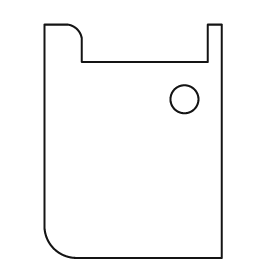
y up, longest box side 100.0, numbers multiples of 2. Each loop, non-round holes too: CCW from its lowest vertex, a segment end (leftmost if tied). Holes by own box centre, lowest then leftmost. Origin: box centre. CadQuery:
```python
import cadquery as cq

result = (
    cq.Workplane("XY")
    .moveTo(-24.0, -50.0)
    .lineTo(38.0, -50.0)
    .lineTo(38.0, 50.0)
    .lineTo(32.0, 50.0)
    .lineTo(32.0, 34.0)
    .lineTo(-22.0, 34.0)
    .lineTo(-22.0, 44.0)
    .threePointArc((-24.0, 48.0), (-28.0, 50.0))
    .lineTo(-38.0, 50.0)
    .lineTo(-38.0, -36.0)
    .threePointArc((-34.0, -46.0), (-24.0, -50.0))
    .close()
    .moveTo(22.0, 18.0)
    .circle(6.0)
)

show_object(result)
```